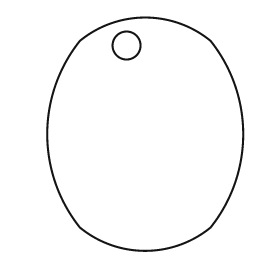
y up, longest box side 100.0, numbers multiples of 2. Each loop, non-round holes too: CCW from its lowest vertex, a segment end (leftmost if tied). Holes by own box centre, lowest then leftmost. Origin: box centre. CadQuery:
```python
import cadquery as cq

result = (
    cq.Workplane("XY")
    .moveTo(-28.0, -40.0)
    .threePointArc((0.0, -50.0), (28.0, -40.0))
    .threePointArc((42.0, 0.0), (28.0, 40.0))
    .threePointArc((0.0, 50.0), (-28.0, 40.0))
    .threePointArc((-42.0, 0.0), (-28.0, -40.0))
    .close()
    .moveTo(-8.0, 38.0)
    .circle(6.0)
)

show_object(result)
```